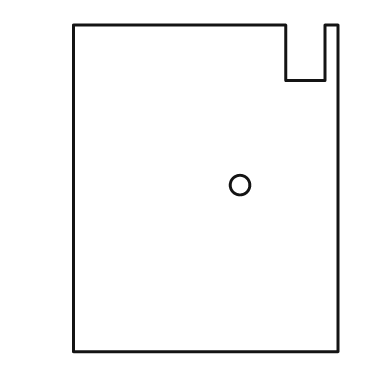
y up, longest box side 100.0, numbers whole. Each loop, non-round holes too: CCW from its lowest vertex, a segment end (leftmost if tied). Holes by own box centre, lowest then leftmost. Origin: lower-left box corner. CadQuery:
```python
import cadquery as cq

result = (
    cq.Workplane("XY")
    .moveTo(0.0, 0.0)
    .lineTo(81.0, 0.0)
    .lineTo(81.0, 100.0)
    .lineTo(77.0, 100.0)
    .lineTo(77.0, 83.0)
    .lineTo(65.0, 83.0)
    .lineTo(65.0, 100.0)
    .lineTo(0.0, 100.0)
    .close()
    .moveTo(51.0, 51.0)
    .circle(3.0)
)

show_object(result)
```